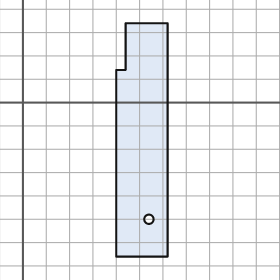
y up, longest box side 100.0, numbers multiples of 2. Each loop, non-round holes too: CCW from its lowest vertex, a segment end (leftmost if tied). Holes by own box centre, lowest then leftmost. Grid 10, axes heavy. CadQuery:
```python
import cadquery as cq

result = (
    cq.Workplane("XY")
    .moveTo(40.0, -66.0)
    .lineTo(62.0, -66.0)
    .lineTo(62.0, 34.0)
    .lineTo(44.0, 34.0)
    .lineTo(44.0, 14.0)
    .lineTo(40.0, 14.0)
    .close()
    .moveTo(54.0, -50.0)
    .circle(2.0)
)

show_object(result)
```